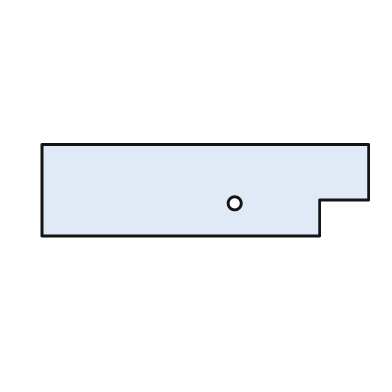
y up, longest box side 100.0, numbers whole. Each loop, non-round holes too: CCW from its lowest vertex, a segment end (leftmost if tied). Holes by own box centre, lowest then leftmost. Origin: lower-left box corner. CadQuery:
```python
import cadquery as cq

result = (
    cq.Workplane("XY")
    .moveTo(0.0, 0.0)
    .lineTo(85.0, 0.0)
    .lineTo(85.0, 11.0)
    .lineTo(100.0, 11.0)
    .lineTo(100.0, 28.0)
    .lineTo(0.0, 28.0)
    .close()
    .moveTo(59.0, 10.0)
    .circle(2.0)
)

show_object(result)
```